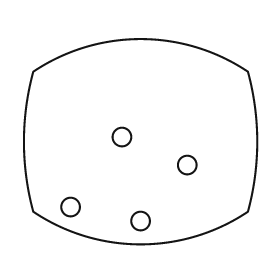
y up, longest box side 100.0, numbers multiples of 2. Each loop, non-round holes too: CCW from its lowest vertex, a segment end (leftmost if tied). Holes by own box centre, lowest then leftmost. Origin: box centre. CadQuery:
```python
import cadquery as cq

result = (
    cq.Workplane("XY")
    .moveTo(-46.0, -30.0)
    .threePointArc((0.0, -44.0), (46.0, -30.0))
    .threePointArc((50.0, 0.0), (46.0, 30.0))
    .threePointArc((0.0, 44.0), (-46.0, 30.0))
    .threePointArc((-50.0, 0.0), (-46.0, -30.0))
    .close()
    .moveTo(0.0, -34.0)
    .circle(4.0)
    .moveTo(-30.0, -28.0)
    .circle(4.0)
    .moveTo(20.0, -10.0)
    .circle(4.0)
    .moveTo(-8.0, 2.0)
    .circle(4.0)
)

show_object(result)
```